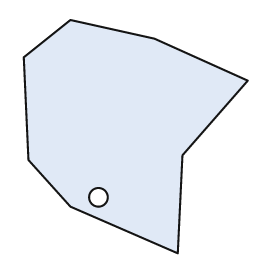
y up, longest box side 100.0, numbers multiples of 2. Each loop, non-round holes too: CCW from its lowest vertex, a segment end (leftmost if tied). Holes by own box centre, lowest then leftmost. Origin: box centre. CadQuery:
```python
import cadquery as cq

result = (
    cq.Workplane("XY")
    .moveTo(18.0, -50.0)
    .lineTo(20.0, -8.0)
    .lineTo(48.0, 24.0)
    .lineTo(8.0, 42.0)
    .lineTo(-28.0, 50.0)
    .lineTo(-48.0, 34.0)
    .lineTo(-46.0, -10.0)
    .lineTo(-28.0, -30.0)
    .close()
    .moveTo(-16.0, -26.0)
    .circle(4.0)
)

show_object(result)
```